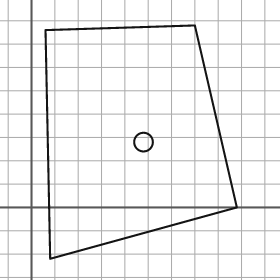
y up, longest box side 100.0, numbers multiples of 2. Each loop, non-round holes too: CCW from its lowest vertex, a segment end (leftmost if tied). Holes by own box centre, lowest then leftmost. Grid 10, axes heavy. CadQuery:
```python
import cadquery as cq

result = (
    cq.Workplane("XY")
    .moveTo(8.0, -22.0)
    .lineTo(88.0, 0.0)
    .lineTo(70.0, 78.0)
    .lineTo(6.0, 76.0)
    .close()
    .moveTo(48.0, 28.0)
    .circle(4.0)
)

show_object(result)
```